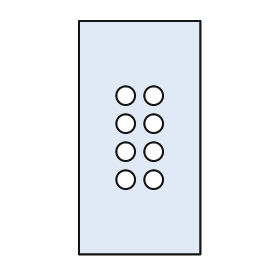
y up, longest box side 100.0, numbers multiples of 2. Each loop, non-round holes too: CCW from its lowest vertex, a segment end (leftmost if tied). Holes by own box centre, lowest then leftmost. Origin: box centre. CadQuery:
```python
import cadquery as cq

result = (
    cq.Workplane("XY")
    .moveTo(-26.0, -50.0)
    .lineTo(26.0, -50.0)
    .lineTo(26.0, 50.0)
    .lineTo(-26.0, 50.0)
    .close()
    .moveTo(-6.0, -18.0)
    .circle(4.0)
    .moveTo(6.0, -18.0)
    .circle(4.0)
    .moveTo(-6.0, -6.0)
    .circle(4.0)
    .moveTo(6.0, -6.0)
    .circle(4.0)
    .moveTo(-6.0, 6.0)
    .circle(4.0)
    .moveTo(6.0, 6.0)
    .circle(4.0)
    .moveTo(-6.0, 18.0)
    .circle(4.0)
    .moveTo(6.0, 18.0)
    .circle(4.0)
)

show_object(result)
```